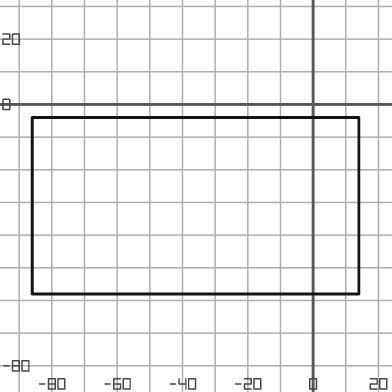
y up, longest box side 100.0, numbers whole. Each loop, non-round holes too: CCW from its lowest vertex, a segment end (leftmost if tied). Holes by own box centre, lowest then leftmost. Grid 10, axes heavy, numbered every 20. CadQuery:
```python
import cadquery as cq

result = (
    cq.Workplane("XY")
    .moveTo(-86.0, -58.0)
    .lineTo(14.0, -58.0)
    .lineTo(14.0, -4.0)
    .lineTo(-86.0, -4.0)
    .close()
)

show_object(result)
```